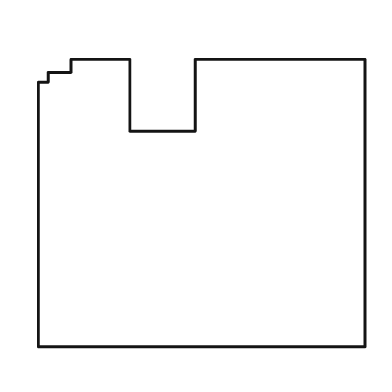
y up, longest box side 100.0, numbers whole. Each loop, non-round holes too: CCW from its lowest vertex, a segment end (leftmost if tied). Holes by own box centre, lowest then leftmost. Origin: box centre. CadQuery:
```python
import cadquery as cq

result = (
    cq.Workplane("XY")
    .moveTo(-50.0, -44.0)
    .lineTo(50.0, -44.0)
    .lineTo(50.0, 44.0)
    .lineTo(-2.0, 44.0)
    .lineTo(-2.0, 22.0)
    .lineTo(-22.0, 22.0)
    .lineTo(-22.0, 44.0)
    .lineTo(-40.0, 44.0)
    .lineTo(-40.0, 40.0)
    .lineTo(-47.0, 40.0)
    .lineTo(-47.0, 37.0)
    .lineTo(-50.0, 37.0)
    .close()
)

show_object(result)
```